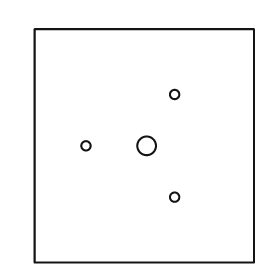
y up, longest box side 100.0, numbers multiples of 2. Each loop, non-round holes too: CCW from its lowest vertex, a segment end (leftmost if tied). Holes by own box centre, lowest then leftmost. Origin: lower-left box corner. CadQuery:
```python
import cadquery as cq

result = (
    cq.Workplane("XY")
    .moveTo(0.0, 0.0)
    .lineTo(94.0, 0.0)
    .lineTo(94.0, 100.0)
    .lineTo(0.0, 100.0)
    .close()
    .moveTo(60.0, 28.0)
    .circle(2.0)
    .moveTo(22.0, 50.0)
    .circle(2.0)
    .moveTo(48.0, 50.0)
    .circle(4.0)
    .moveTo(60.0, 72.0)
    .circle(2.0)
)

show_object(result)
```